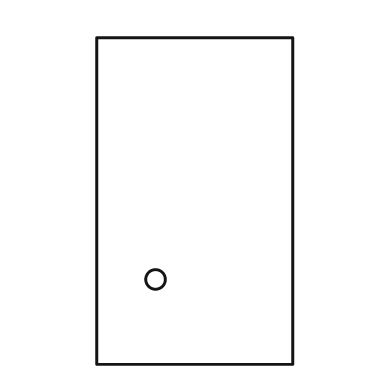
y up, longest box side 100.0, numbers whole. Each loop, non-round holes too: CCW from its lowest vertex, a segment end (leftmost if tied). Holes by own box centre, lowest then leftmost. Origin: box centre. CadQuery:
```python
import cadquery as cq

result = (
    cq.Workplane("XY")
    .moveTo(-30.0, -50.0)
    .lineTo(30.0, -50.0)
    .lineTo(30.0, 50.0)
    .lineTo(-30.0, 50.0)
    .close()
    .moveTo(-12.0, -24.0)
    .circle(3.0)
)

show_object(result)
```